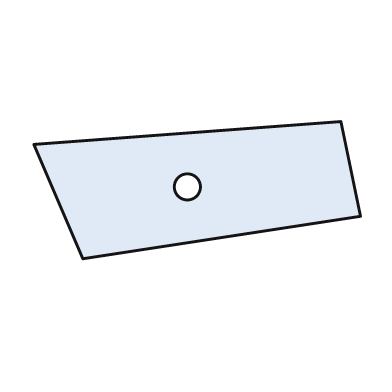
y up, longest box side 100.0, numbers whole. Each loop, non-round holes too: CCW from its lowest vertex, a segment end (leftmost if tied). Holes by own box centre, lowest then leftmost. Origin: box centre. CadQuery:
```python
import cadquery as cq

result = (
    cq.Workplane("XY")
    .moveTo(-35.0, -21.0)
    .lineTo(50.0, -8.0)
    .lineTo(44.0, 21.0)
    .lineTo(-50.0, 14.0)
    .close()
    .moveTo(-3.0, 1.0)
    .circle(4.0)
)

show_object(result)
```